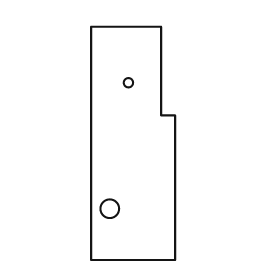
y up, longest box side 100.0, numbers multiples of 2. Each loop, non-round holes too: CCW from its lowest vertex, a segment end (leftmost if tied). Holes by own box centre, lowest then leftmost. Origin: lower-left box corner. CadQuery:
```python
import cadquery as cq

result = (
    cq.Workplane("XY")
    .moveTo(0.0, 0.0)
    .lineTo(36.0, 0.0)
    .lineTo(36.0, 62.0)
    .lineTo(30.0, 62.0)
    .lineTo(30.0, 100.0)
    .lineTo(0.0, 100.0)
    .close()
    .moveTo(8.0, 22.0)
    .circle(4.0)
    .moveTo(16.0, 76.0)
    .circle(2.0)
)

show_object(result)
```